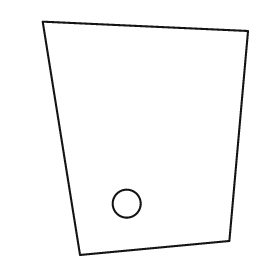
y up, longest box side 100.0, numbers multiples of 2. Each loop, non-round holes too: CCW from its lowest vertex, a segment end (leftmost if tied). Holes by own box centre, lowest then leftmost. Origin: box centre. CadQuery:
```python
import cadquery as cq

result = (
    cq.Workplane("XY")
    .moveTo(-28.0, -50.0)
    .lineTo(36.0, -44.0)
    .lineTo(44.0, 46.0)
    .lineTo(-44.0, 50.0)
    .close()
    .moveTo(-8.0, -28.0)
    .circle(6.0)
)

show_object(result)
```